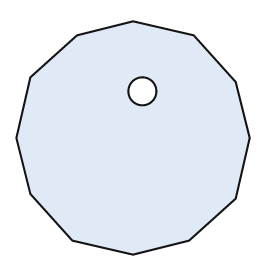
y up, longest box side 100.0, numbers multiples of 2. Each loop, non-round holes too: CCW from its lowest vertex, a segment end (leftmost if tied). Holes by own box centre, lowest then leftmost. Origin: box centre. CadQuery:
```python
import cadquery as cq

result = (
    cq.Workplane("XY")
    .moveTo(0.0, -50.0)
    .lineTo(24.0, -44.0)
    .lineTo(44.0, -26.0)
    .lineTo(50.0, 0.0)
    .lineTo(44.0, 24.0)
    .lineTo(26.0, 44.0)
    .lineTo(0.0, 50.0)
    .lineTo(-24.0, 44.0)
    .lineTo(-44.0, 26.0)
    .lineTo(-50.0, 0.0)
    .lineTo(-44.0, -24.0)
    .lineTo(-26.0, -44.0)
    .close()
    .moveTo(4.0, 20.0)
    .circle(6.0)
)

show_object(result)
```